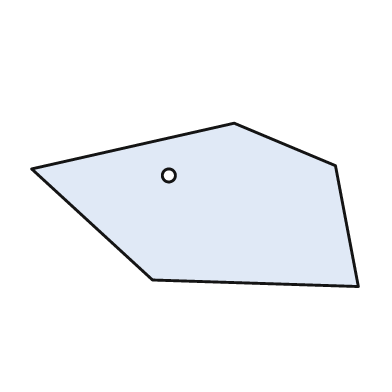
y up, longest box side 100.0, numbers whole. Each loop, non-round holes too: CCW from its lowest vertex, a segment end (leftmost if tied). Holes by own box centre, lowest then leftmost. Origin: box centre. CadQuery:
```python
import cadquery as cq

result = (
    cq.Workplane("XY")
    .moveTo(50.0, -25.0)
    .lineTo(43.0, 12.0)
    .lineTo(12.0, 25.0)
    .lineTo(-50.0, 11.0)
    .lineTo(-13.0, -23.0)
    .close()
    .moveTo(-8.0, 9.0)
    .circle(2.0)
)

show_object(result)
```